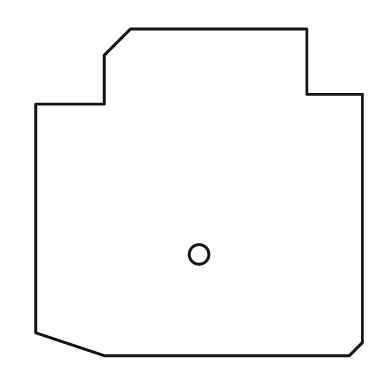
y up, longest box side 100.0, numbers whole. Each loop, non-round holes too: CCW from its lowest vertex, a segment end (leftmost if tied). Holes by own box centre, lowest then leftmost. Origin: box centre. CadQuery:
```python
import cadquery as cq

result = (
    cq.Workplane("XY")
    .moveTo(-29.0, -50.0)
    .lineTo(46.0, -50.0)
    .lineTo(50.0, -46.0)
    .lineTo(50.0, 30.0)
    .lineTo(33.0, 30.0)
    .lineTo(33.0, 50.0)
    .lineTo(-21.0, 50.0)
    .lineTo(-29.0, 42.0)
    .lineTo(-29.0, 27.0)
    .lineTo(-50.0, 27.0)
    .lineTo(-50.0, -43.0)
    .close()
    .moveTo(0.0, -19.0)
    .circle(3.0)
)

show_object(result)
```